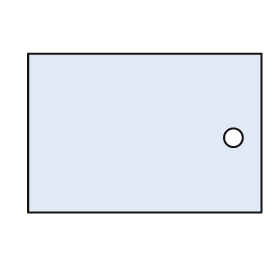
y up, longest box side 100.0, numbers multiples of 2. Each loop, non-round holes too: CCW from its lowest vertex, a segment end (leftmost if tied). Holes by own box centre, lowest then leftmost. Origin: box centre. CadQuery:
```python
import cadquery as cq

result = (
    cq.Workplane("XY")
    .moveTo(-50.0, -34.0)
    .lineTo(50.0, -34.0)
    .lineTo(50.0, 34.0)
    .lineTo(-50.0, 34.0)
    .close()
    .moveTo(38.0, -2.0)
    .circle(4.0)
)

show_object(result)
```